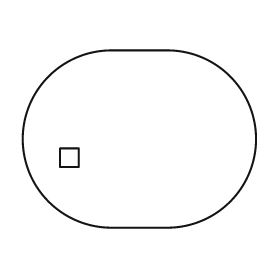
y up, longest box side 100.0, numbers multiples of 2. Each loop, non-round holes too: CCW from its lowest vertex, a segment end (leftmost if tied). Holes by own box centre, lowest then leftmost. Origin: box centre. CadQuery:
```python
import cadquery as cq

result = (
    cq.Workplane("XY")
    .moveTo(-12.0, -38.0)
    .lineTo(12.0, -38.0)
    .threePointArc((50.0, 0.0), (12.0, 38.0))
    .lineTo(-12.0, 38.0)
    .threePointArc((-50.0, 0.0), (-12.0, -38.0))
    .close()
    .moveTo(-34.0, -12.0)
    .lineTo(-26.0, -12.0)
    .lineTo(-26.0, -4.0)
    .lineTo(-34.0, -4.0)
    .close()
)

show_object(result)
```